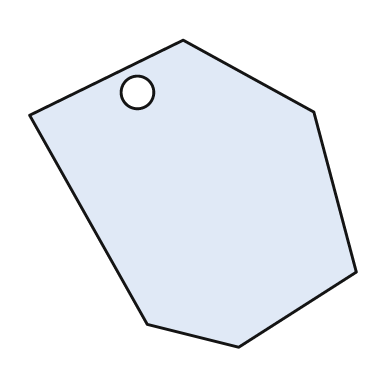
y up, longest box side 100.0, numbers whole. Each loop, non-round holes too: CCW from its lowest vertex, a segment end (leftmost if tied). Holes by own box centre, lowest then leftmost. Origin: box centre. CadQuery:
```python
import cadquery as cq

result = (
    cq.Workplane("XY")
    .moveTo(14.0, -47.0)
    .lineTo(50.0, -24.0)
    .lineTo(37.0, 25.0)
    .lineTo(-3.0, 47.0)
    .lineTo(-50.0, 24.0)
    .lineTo(-14.0, -40.0)
    .close()
    .moveTo(-17.0, 31.0)
    .circle(5.0)
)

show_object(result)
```